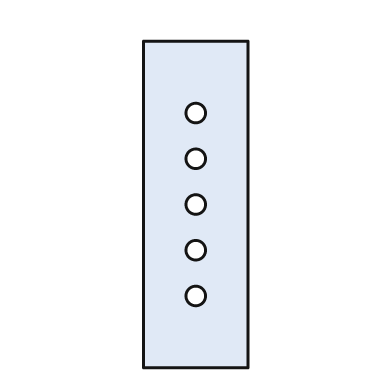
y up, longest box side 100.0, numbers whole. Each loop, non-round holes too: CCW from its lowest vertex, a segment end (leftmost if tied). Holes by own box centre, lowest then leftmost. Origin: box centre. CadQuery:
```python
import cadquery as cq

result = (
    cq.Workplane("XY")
    .moveTo(-16.0, -50.0)
    .lineTo(16.0, -50.0)
    .lineTo(16.0, 50.0)
    .lineTo(-16.0, 50.0)
    .close()
    .moveTo(0.0, -28.0)
    .circle(3.0)
    .moveTo(0.0, -14.0)
    .circle(3.0)
    .moveTo(0.0, 0.0)
    .circle(3.0)
    .moveTo(0.0, 14.0)
    .circle(3.0)
    .moveTo(0.0, 28.0)
    .circle(3.0)
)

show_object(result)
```